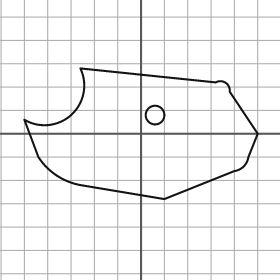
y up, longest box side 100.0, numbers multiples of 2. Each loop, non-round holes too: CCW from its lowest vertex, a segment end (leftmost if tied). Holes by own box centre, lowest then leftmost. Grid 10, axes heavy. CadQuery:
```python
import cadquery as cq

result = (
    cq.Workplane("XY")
    .moveTo(10.0, -28.0)
    .lineTo(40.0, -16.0)
    .threePointArc((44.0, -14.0), (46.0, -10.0))
    .lineTo(50.0, 0.0)
    .lineTo(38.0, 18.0)
    .threePointArc((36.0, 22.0), (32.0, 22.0))
    .lineTo(-26.0, 28.0)
    .threePointArc((-30.0, 8.0), (-50.0, 6.0))
    .lineTo(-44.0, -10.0)
    .threePointArc((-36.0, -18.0), (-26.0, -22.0))
    .close()
    .moveTo(6.0, 8.0)
    .circle(4.0)
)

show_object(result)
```